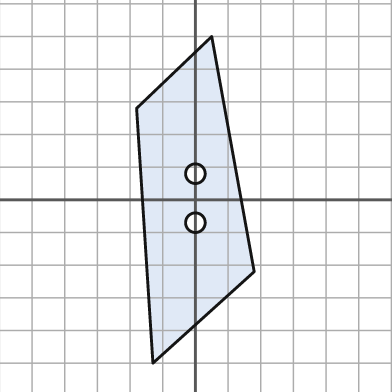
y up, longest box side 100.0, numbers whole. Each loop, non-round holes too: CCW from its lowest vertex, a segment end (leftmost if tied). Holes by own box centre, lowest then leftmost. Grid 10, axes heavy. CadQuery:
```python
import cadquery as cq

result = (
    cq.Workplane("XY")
    .moveTo(-13.0, -50.0)
    .lineTo(18.0, -22.0)
    .lineTo(5.0, 50.0)
    .lineTo(-18.0, 28.0)
    .close()
    .moveTo(0.0, -7.0)
    .circle(3.0)
    .moveTo(0.0, 8.0)
    .circle(3.0)
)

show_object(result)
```